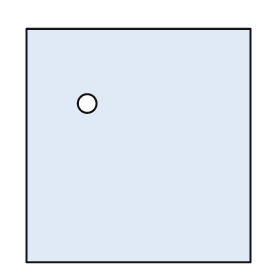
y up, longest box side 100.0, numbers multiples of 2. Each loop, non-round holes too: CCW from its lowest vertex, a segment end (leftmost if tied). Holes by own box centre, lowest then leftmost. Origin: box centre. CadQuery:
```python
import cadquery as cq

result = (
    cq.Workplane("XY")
    .moveTo(-48.0, -50.0)
    .lineTo(48.0, -50.0)
    .lineTo(48.0, 50.0)
    .lineTo(-48.0, 50.0)
    .close()
    .moveTo(-22.0, 18.0)
    .circle(4.0)
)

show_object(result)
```